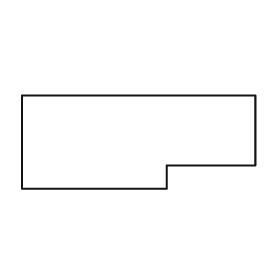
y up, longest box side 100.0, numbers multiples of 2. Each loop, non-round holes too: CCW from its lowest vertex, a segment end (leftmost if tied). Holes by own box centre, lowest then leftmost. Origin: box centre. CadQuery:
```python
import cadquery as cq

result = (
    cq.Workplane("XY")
    .moveTo(-50.0, -20.0)
    .lineTo(12.0, -20.0)
    .lineTo(12.0, -10.0)
    .lineTo(50.0, -10.0)
    .lineTo(50.0, 20.0)
    .lineTo(-50.0, 20.0)
    .close()
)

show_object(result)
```